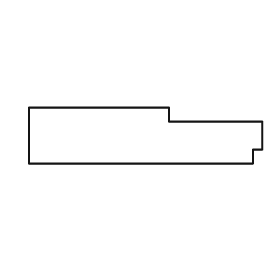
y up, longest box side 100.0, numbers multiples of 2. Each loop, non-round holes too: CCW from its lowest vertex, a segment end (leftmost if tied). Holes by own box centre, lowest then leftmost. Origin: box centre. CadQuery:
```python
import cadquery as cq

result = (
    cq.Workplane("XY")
    .moveTo(-50.0, -12.0)
    .lineTo(46.0, -12.0)
    .lineTo(46.0, -6.0)
    .lineTo(50.0, -6.0)
    .lineTo(50.0, 6.0)
    .lineTo(10.0, 6.0)
    .lineTo(10.0, 12.0)
    .lineTo(-50.0, 12.0)
    .close()
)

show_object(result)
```